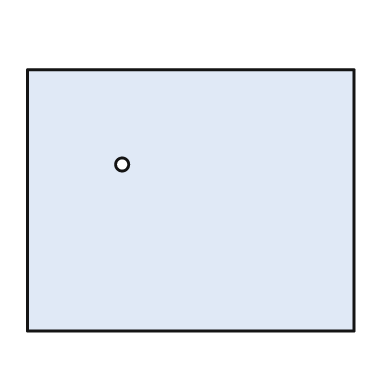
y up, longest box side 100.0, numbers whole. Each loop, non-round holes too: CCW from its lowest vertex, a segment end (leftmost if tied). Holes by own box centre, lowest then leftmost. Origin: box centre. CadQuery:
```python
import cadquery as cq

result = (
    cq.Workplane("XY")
    .moveTo(-50.0, -40.0)
    .lineTo(50.0, -40.0)
    .lineTo(50.0, 40.0)
    .lineTo(-50.0, 40.0)
    .close()
    .moveTo(-21.0, 11.0)
    .circle(2.0)
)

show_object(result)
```